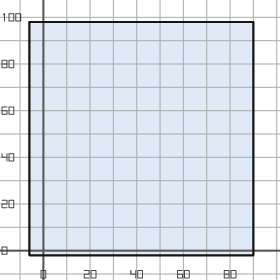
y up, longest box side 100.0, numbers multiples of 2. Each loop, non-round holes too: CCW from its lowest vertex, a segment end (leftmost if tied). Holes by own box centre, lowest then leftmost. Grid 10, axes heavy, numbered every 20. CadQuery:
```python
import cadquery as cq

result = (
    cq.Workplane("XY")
    .moveTo(-6.0, -2.0)
    .lineTo(90.0, -2.0)
    .lineTo(90.0, 98.0)
    .lineTo(-6.0, 98.0)
    .close()
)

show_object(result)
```